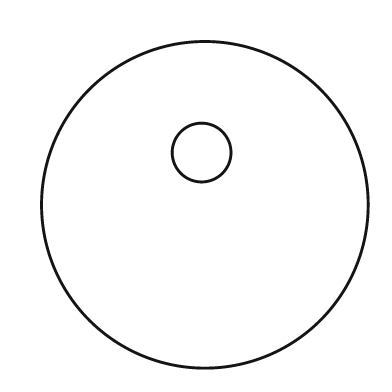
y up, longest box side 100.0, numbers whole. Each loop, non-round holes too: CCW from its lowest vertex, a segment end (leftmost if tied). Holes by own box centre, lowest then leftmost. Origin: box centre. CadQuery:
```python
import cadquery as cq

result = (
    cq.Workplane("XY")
    .moveTo(0.0, 0.0)
    .circle(50.0)
    .moveTo(-1.0, 16.0)
    .circle(9.0)
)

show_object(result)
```